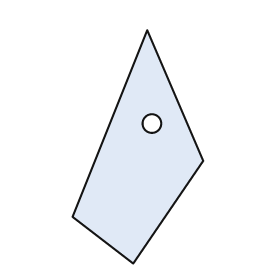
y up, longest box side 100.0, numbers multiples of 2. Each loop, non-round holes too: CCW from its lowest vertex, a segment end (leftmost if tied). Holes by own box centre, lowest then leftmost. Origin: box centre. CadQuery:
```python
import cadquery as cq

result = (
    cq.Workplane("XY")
    .moveTo(-2.0, -50.0)
    .lineTo(28.0, -6.0)
    .lineTo(4.0, 50.0)
    .lineTo(-28.0, -30.0)
    .close()
    .moveTo(6.0, 10.0)
    .circle(4.0)
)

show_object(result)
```